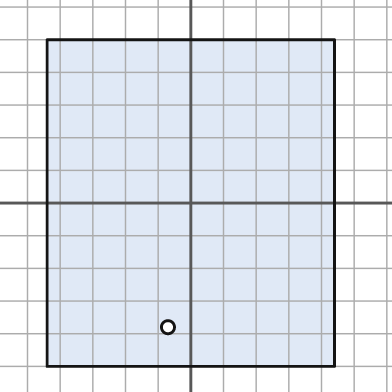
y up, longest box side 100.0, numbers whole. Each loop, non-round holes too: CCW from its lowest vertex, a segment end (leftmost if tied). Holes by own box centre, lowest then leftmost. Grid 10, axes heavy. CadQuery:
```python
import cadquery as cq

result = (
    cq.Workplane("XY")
    .moveTo(-44.0, -50.0)
    .lineTo(44.0, -50.0)
    .lineTo(44.0, 50.0)
    .lineTo(-44.0, 50.0)
    .close()
    .moveTo(-7.0, -38.0)
    .circle(2.0)
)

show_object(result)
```